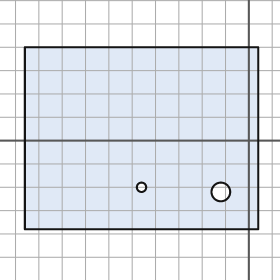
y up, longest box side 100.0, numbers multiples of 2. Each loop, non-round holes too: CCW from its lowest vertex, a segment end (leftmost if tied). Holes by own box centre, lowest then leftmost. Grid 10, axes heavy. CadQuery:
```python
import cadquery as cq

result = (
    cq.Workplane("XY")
    .moveTo(-96.0, -38.0)
    .lineTo(4.0, -38.0)
    .lineTo(4.0, 40.0)
    .lineTo(-96.0, 40.0)
    .close()
    .moveTo(-12.0, -22.0)
    .circle(4.0)
    .moveTo(-46.0, -20.0)
    .circle(2.0)
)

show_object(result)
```